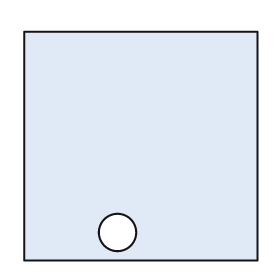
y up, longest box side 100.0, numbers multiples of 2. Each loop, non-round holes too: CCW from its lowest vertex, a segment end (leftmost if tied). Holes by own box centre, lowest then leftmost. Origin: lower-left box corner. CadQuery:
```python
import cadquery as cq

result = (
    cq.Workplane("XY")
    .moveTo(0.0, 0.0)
    .lineTo(100.0, 0.0)
    .lineTo(100.0, 98.0)
    .lineTo(0.0, 98.0)
    .close()
    .moveTo(40.0, 12.0)
    .circle(8.0)
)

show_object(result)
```